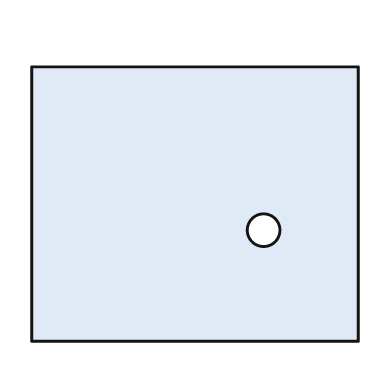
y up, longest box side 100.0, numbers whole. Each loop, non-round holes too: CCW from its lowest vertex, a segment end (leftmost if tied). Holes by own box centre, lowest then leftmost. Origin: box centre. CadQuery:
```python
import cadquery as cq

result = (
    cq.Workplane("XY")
    .moveTo(-50.0, -42.0)
    .lineTo(50.0, -42.0)
    .lineTo(50.0, 42.0)
    .lineTo(-50.0, 42.0)
    .close()
    .moveTo(21.0, -8.0)
    .circle(5.0)
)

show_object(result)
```